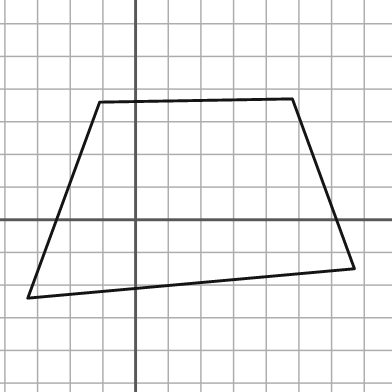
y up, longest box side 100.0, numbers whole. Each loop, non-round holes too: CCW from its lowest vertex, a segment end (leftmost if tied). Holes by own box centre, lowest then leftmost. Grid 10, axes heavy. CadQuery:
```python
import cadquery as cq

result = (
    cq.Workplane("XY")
    .moveTo(-33.0, -24.0)
    .lineTo(67.0, -15.0)
    .lineTo(48.0, 37.0)
    .lineTo(-11.0, 36.0)
    .close()
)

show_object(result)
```